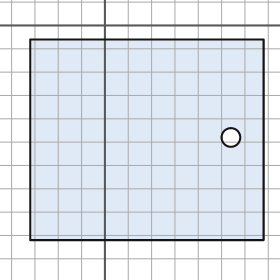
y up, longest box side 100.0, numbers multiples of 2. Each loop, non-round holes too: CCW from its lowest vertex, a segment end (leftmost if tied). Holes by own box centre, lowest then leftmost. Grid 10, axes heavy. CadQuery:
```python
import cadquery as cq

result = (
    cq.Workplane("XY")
    .moveTo(-32.0, -92.0)
    .lineTo(68.0, -92.0)
    .lineTo(68.0, -6.0)
    .lineTo(-32.0, -6.0)
    .close()
    .moveTo(54.0, -48.0)
    .circle(4.0)
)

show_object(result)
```